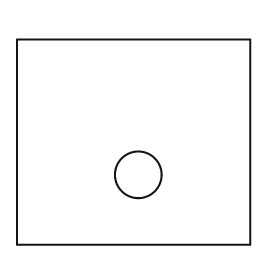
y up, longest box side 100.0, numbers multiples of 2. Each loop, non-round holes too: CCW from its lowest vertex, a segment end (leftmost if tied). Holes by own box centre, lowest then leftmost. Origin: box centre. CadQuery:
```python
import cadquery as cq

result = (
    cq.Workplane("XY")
    .moveTo(-50.0, -44.0)
    .lineTo(50.0, -44.0)
    .lineTo(50.0, 44.0)
    .lineTo(-50.0, 44.0)
    .close()
    .moveTo(2.0, -14.0)
    .circle(10.0)
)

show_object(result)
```